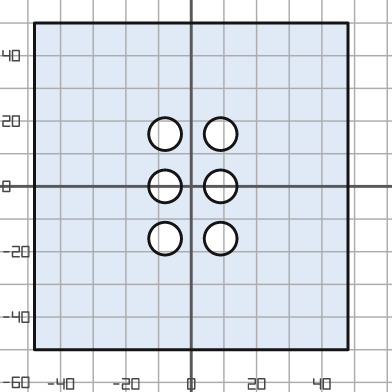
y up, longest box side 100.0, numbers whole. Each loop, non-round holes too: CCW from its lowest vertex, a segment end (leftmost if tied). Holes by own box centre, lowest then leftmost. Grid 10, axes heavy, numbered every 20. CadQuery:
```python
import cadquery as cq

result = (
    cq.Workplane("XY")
    .moveTo(-48.0, -50.0)
    .lineTo(48.0, -50.0)
    .lineTo(48.0, 50.0)
    .lineTo(-48.0, 50.0)
    .close()
    .moveTo(-8.0, -16.0)
    .circle(5.0)
    .moveTo(9.0, -16.0)
    .circle(5.0)
    .moveTo(-8.0, 0.0)
    .circle(5.0)
    .moveTo(9.0, 0.0)
    .circle(5.0)
    .moveTo(-8.0, 16.0)
    .circle(5.0)
    .moveTo(9.0, 16.0)
    .circle(5.0)
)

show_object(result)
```